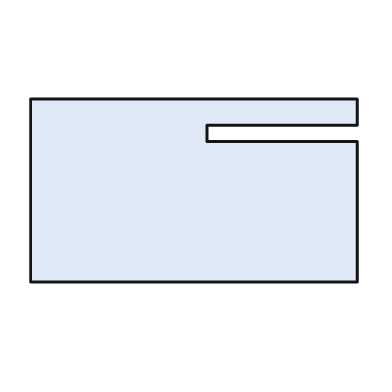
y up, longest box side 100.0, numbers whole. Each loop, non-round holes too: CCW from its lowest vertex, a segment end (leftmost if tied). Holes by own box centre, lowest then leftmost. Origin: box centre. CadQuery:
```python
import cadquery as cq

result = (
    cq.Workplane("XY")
    .moveTo(-50.0, -28.0)
    .lineTo(50.0, -28.0)
    .lineTo(50.0, 15.0)
    .lineTo(4.0, 15.0)
    .lineTo(4.0, 20.0)
    .lineTo(50.0, 20.0)
    .lineTo(50.0, 28.0)
    .lineTo(-50.0, 28.0)
    .close()
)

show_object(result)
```